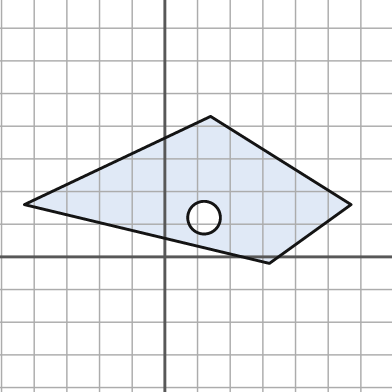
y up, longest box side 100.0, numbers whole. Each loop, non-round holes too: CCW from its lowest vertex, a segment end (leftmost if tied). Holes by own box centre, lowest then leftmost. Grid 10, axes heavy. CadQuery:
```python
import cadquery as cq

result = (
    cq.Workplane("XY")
    .moveTo(32.0, -2.0)
    .lineTo(57.0, 16.0)
    .lineTo(14.0, 43.0)
    .lineTo(-43.0, 16.0)
    .close()
    .moveTo(12.0, 12.0)
    .circle(5.0)
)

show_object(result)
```